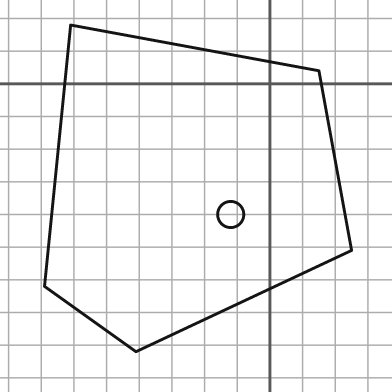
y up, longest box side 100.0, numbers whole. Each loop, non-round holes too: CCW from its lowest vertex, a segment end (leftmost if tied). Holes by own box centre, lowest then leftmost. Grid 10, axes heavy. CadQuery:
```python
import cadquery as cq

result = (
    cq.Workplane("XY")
    .moveTo(-41.0, -82.0)
    .lineTo(25.0, -51.0)
    .lineTo(15.0, 4.0)
    .lineTo(-61.0, 18.0)
    .lineTo(-69.0, -62.0)
    .close()
    .moveTo(-12.0, -40.0)
    .circle(4.0)
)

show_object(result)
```